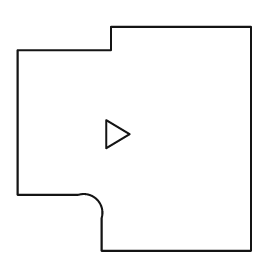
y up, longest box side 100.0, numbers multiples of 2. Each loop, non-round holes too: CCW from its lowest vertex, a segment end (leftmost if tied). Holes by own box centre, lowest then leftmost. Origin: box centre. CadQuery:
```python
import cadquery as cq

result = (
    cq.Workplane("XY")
    .moveTo(-14.0, -48.0)
    .lineTo(50.0, -48.0)
    .lineTo(50.0, 48.0)
    .lineTo(-10.0, 48.0)
    .lineTo(-10.0, 38.0)
    .lineTo(-50.0, 38.0)
    .lineTo(-50.0, -24.0)
    .lineTo(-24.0, -24.0)
    .threePointArc((-16.0, -26.0), (-14.0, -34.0))
    .close()
    .moveTo(-12.0, -4.0)
    .lineTo(-2.0, 2.0)
    .lineTo(-12.0, 8.0)
    .close()
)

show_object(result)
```